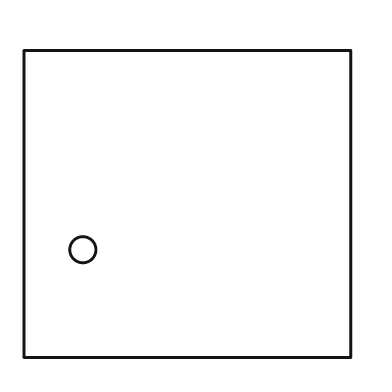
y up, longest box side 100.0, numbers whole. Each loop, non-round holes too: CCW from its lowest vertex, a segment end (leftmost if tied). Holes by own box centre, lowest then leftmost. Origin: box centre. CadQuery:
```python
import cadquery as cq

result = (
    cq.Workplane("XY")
    .moveTo(-50.0, -47.0)
    .lineTo(50.0, -47.0)
    .lineTo(50.0, 47.0)
    .lineTo(-50.0, 47.0)
    .close()
    .moveTo(-32.0, -14.0)
    .circle(4.0)
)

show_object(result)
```